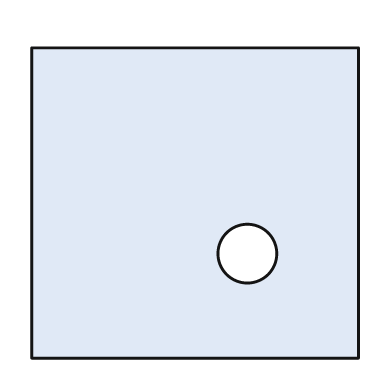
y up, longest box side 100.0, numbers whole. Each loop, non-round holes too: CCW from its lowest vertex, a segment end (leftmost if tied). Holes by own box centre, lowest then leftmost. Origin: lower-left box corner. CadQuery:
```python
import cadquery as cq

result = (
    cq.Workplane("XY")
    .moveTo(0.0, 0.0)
    .lineTo(100.0, 0.0)
    .lineTo(100.0, 95.0)
    .lineTo(0.0, 95.0)
    .close()
    .moveTo(66.0, 32.0)
    .circle(9.0)
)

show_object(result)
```